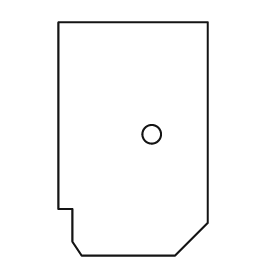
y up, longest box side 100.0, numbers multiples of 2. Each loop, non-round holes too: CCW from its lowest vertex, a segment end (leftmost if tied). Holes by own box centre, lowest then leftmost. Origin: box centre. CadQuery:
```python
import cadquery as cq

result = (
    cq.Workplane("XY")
    .moveTo(-22.0, -50.0)
    .lineTo(18.0, -50.0)
    .lineTo(32.0, -36.0)
    .lineTo(32.0, 50.0)
    .lineTo(-32.0, 50.0)
    .lineTo(-32.0, -30.0)
    .lineTo(-26.0, -30.0)
    .lineTo(-26.0, -44.0)
    .close()
    .moveTo(8.0, 2.0)
    .circle(4.0)
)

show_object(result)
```